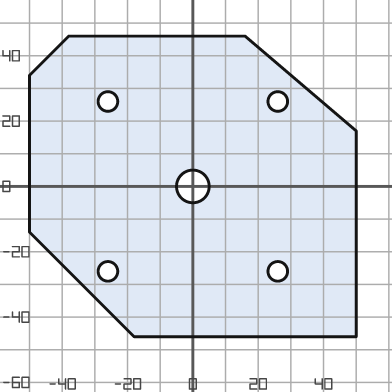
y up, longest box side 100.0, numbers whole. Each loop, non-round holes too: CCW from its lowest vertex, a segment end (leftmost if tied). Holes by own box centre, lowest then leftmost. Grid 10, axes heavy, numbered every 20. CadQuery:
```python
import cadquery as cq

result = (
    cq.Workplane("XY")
    .moveTo(-18.0, -46.0)
    .lineTo(50.0, -46.0)
    .lineTo(50.0, 17.0)
    .lineTo(16.0, 46.0)
    .lineTo(-38.0, 46.0)
    .lineTo(-50.0, 34.0)
    .lineTo(-50.0, -14.0)
    .close()
    .moveTo(-26.0, -26.0)
    .circle(3.0)
    .moveTo(26.0, -26.0)
    .circle(3.0)
    .moveTo(0.0, 0.0)
    .circle(5.0)
    .moveTo(-26.0, 26.0)
    .circle(3.0)
    .moveTo(26.0, 26.0)
    .circle(3.0)
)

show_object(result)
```